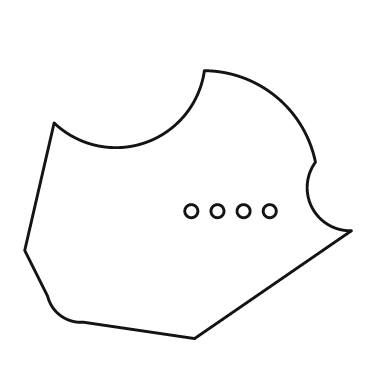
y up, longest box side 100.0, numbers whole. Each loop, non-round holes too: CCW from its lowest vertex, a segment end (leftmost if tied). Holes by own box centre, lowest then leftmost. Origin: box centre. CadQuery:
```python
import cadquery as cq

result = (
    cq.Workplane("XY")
    .moveTo(2.0, -41.0)
    .lineTo(50.0, -8.0)
    .threePointArc((38.0, -1.0), (39.0, 13.0))
    .threePointArc((27.0, 33.0), (5.0, 41.0))
    .threePointArc((-13.0, 19.0), (-41.0, 25.0))
    .lineTo(-50.0, -14.0)
    .lineTo(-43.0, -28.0)
    .threePointArc((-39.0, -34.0), (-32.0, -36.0))
    .close()
    .moveTo(1.0, -2.0)
    .circle(2.0)
    .moveTo(9.0, -2.0)
    .circle(2.0)
    .moveTo(17.0, -2.0)
    .circle(2.0)
    .moveTo(25.0, -2.0)
    .circle(2.0)
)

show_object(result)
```